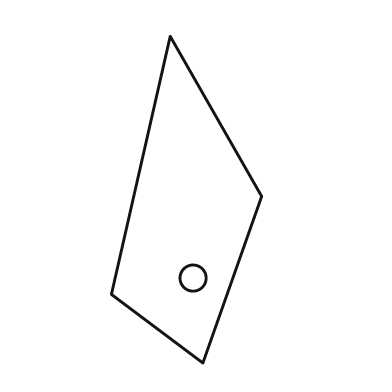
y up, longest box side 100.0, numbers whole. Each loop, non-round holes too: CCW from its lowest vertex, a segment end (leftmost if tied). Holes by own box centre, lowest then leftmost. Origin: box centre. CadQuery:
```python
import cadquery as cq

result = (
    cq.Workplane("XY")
    .moveTo(5.0, -50.0)
    .lineTo(23.0, 1.0)
    .lineTo(-5.0, 50.0)
    .lineTo(-23.0, -29.0)
    .close()
    .moveTo(2.0, -24.0)
    .circle(4.0)
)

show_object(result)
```